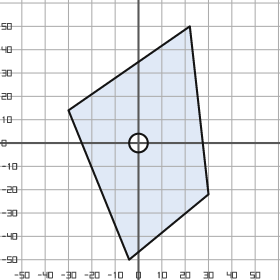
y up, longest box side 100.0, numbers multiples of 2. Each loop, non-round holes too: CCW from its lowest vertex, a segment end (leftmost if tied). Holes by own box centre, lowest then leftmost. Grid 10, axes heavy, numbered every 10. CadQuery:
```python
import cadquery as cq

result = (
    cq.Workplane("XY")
    .moveTo(-4.0, -50.0)
    .lineTo(30.0, -22.0)
    .lineTo(22.0, 50.0)
    .lineTo(-30.0, 14.0)
    .close()
    .moveTo(0.0, 0.0)
    .circle(4.0)
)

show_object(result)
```